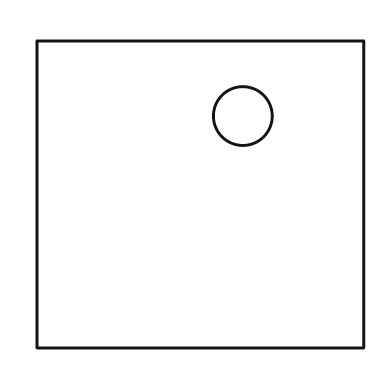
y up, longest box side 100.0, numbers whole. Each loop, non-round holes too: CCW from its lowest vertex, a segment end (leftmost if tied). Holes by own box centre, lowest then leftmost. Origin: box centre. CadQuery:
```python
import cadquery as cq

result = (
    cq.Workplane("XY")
    .moveTo(-50.0, -47.0)
    .lineTo(50.0, -47.0)
    .lineTo(50.0, 47.0)
    .lineTo(-50.0, 47.0)
    .close()
    .moveTo(13.0, 24.0)
    .circle(9.0)
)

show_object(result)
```